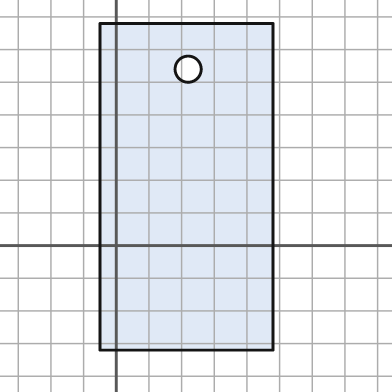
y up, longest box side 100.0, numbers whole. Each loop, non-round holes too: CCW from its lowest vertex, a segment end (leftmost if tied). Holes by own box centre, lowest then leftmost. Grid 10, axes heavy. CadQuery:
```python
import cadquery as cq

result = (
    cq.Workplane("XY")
    .moveTo(-5.0, -32.0)
    .lineTo(48.0, -32.0)
    .lineTo(48.0, 68.0)
    .lineTo(-5.0, 68.0)
    .close()
    .moveTo(22.0, 54.0)
    .circle(4.0)
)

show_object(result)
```